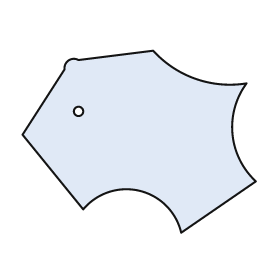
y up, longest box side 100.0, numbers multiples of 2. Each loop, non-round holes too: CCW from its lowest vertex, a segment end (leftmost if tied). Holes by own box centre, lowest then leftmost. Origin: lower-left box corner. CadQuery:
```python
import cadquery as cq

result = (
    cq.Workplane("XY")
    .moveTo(68.0, 0.0)
    .lineTo(100.0, 22.0)
    .threePointArc((90.0, 42.0), (96.0, 64.0))
    .threePointArc((74.0, 66.0), (56.0, 78.0))
    .lineTo(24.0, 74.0)
    .threePointArc((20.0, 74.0), (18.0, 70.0))
    .lineTo(0.0, 42.0)
    .lineTo(26.0, 10.0)
    .threePointArc((50.0, 18.0), (68.0, 0.0))
    .close()
    .moveTo(24.0, 52.0)
    .circle(2.0)
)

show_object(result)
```